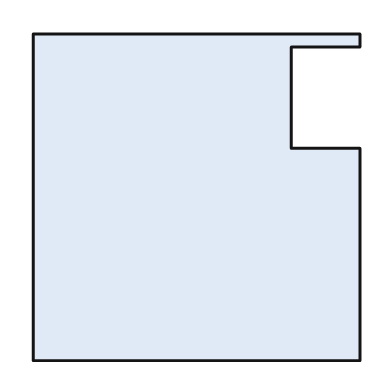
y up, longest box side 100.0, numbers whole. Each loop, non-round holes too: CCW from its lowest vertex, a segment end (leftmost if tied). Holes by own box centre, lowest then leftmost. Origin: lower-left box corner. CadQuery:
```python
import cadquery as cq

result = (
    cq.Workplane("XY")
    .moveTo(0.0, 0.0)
    .lineTo(100.0, 0.0)
    .lineTo(100.0, 65.0)
    .lineTo(79.0, 65.0)
    .lineTo(79.0, 96.0)
    .lineTo(100.0, 96.0)
    .lineTo(100.0, 100.0)
    .lineTo(0.0, 100.0)
    .close()
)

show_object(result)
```